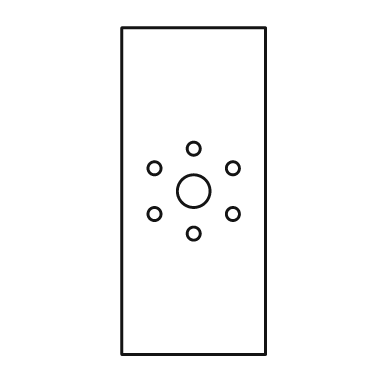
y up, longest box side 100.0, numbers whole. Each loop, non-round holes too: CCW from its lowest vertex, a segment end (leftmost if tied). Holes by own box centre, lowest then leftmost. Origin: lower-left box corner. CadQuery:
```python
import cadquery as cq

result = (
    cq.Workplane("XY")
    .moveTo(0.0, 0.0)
    .lineTo(44.0, 0.0)
    .lineTo(44.0, 100.0)
    .lineTo(0.0, 100.0)
    .close()
    .moveTo(22.0, 37.0)
    .circle(2.0)
    .moveTo(10.0, 43.0)
    .circle(2.0)
    .moveTo(34.0, 43.0)
    .circle(2.0)
    .moveTo(22.0, 50.0)
    .circle(5.0)
    .moveTo(10.0, 57.0)
    .circle(2.0)
    .moveTo(34.0, 57.0)
    .circle(2.0)
    .moveTo(22.0, 63.0)
    .circle(2.0)
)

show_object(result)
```